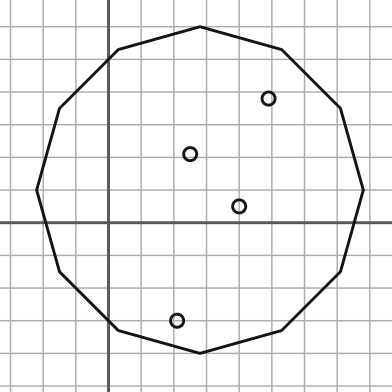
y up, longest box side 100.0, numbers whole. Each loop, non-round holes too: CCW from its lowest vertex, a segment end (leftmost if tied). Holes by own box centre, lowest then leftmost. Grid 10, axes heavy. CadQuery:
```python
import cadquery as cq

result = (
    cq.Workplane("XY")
    .moveTo(28.0, -40.0)
    .lineTo(53.0, -33.0)
    .lineTo(71.0, -15.0)
    .lineTo(78.0, 10.0)
    .lineTo(71.0, 35.0)
    .lineTo(53.0, 53.0)
    .lineTo(28.0, 60.0)
    .lineTo(3.0, 53.0)
    .lineTo(-15.0, 35.0)
    .lineTo(-22.0, 10.0)
    .lineTo(-15.0, -15.0)
    .lineTo(3.0, -33.0)
    .close()
    .moveTo(21.0, -30.0)
    .circle(2.0)
    .moveTo(40.0, 5.0)
    .circle(2.0)
    .moveTo(25.0, 21.0)
    .circle(2.0)
    .moveTo(49.0, 38.0)
    .circle(2.0)
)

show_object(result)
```